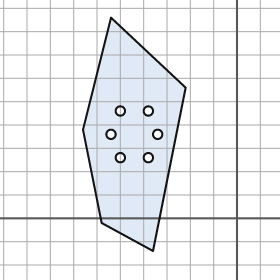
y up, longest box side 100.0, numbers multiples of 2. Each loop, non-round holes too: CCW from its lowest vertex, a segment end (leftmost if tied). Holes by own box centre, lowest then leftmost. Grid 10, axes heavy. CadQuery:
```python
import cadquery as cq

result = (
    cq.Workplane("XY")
    .moveTo(-36.0, -14.0)
    .lineTo(-22.0, 56.0)
    .lineTo(-54.0, 86.0)
    .lineTo(-66.0, 38.0)
    .lineTo(-58.0, -2.0)
    .close()
    .moveTo(-50.0, 26.0)
    .circle(2.0)
    .moveTo(-38.0, 26.0)
    .circle(2.0)
    .moveTo(-54.0, 36.0)
    .circle(2.0)
    .moveTo(-34.0, 36.0)
    .circle(2.0)
    .moveTo(-50.0, 46.0)
    .circle(2.0)
    .moveTo(-38.0, 46.0)
    .circle(2.0)
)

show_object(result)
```